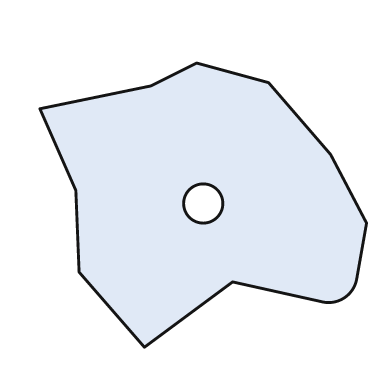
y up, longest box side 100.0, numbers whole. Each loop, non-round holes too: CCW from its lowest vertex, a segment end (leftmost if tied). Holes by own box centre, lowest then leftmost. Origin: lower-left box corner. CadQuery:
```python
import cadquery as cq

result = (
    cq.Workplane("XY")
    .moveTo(32.0, 0.0)
    .lineTo(59.0, 20.0)
    .lineTo(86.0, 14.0)
    .threePointArc((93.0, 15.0), (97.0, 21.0))
    .lineTo(100.0, 38.0)
    .lineTo(89.0, 59.0)
    .lineTo(70.0, 81.0)
    .lineTo(48.0, 87.0)
    .lineTo(34.0, 80.0)
    .lineTo(0.0, 73.0)
    .lineTo(11.0, 48.0)
    .lineTo(12.0, 23.0)
    .close()
    .moveTo(50.0, 44.0)
    .circle(6.0)
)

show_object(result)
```